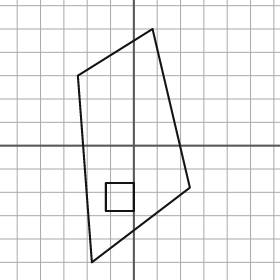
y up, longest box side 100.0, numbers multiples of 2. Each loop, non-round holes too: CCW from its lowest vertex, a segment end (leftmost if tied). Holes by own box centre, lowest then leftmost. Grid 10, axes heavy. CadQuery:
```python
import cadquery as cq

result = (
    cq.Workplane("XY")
    .moveTo(-18.0, -50.0)
    .lineTo(24.0, -18.0)
    .lineTo(8.0, 50.0)
    .lineTo(-24.0, 30.0)
    .close()
    .moveTo(-12.0, -28.0)
    .lineTo(0.0, -28.0)
    .lineTo(0.0, -16.0)
    .lineTo(-12.0, -16.0)
    .close()
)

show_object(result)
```